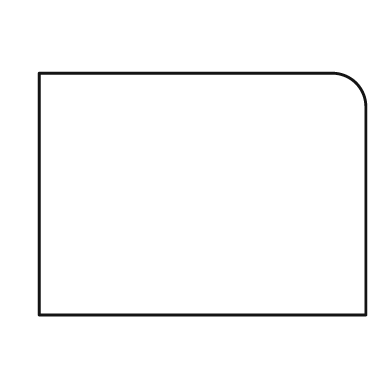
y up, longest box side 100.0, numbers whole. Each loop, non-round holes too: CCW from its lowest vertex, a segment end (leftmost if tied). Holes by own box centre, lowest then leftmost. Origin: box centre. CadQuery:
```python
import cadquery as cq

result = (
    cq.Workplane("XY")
    .moveTo(-50.0, -37.0)
    .lineTo(50.0, -37.0)
    .lineTo(50.0, 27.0)
    .threePointArc((47.0, 34.0), (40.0, 37.0))
    .lineTo(-50.0, 37.0)
    .close()
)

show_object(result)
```